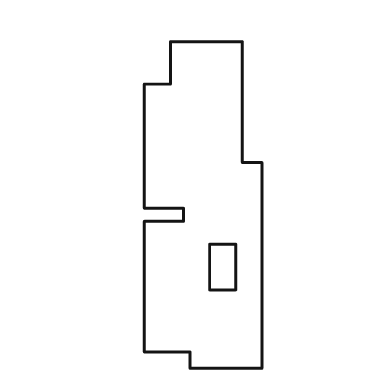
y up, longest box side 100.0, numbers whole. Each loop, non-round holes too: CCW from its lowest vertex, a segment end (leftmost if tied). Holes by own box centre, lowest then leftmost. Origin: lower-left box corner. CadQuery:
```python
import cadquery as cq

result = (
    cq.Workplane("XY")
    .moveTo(14.0, 0.0)
    .lineTo(36.0, 0.0)
    .lineTo(36.0, 63.0)
    .lineTo(30.0, 63.0)
    .lineTo(30.0, 100.0)
    .lineTo(8.0, 100.0)
    .lineTo(8.0, 87.0)
    .lineTo(0.0, 87.0)
    .lineTo(0.0, 49.0)
    .lineTo(12.0, 49.0)
    .lineTo(12.0, 45.0)
    .lineTo(0.0, 45.0)
    .lineTo(0.0, 5.0)
    .lineTo(14.0, 5.0)
    .close()
    .moveTo(20.0, 24.0)
    .lineTo(28.0, 24.0)
    .lineTo(28.0, 38.0)
    .lineTo(20.0, 38.0)
    .close()
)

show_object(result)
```